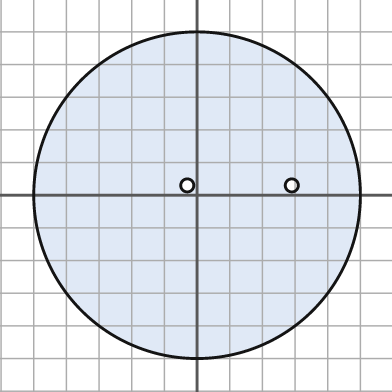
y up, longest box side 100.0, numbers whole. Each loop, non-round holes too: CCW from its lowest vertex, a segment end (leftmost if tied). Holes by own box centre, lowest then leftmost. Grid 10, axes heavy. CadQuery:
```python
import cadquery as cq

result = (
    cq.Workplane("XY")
    .moveTo(0.0, 0.0)
    .circle(50.0)
    .moveTo(-3.0, 3.0)
    .circle(2.0)
    .moveTo(29.0, 3.0)
    .circle(2.0)
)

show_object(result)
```